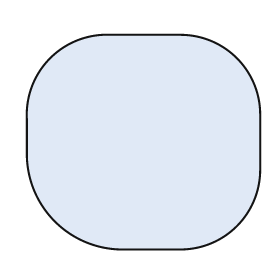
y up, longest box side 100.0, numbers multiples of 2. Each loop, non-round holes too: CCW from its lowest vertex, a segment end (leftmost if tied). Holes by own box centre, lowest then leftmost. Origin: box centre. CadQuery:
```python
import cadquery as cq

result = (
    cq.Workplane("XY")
    .moveTo(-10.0, -46.0)
    .lineTo(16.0, -46.0)
    .threePointArc((40.0, -36.0), (50.0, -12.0))
    .lineTo(50.0, 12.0)
    .threePointArc((40.0, 36.0), (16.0, 46.0))
    .lineTo(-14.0, 46.0)
    .threePointArc((-40.0, 36.0), (-50.0, 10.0))
    .lineTo(-50.0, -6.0)
    .threePointArc((-38.0, -34.0), (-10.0, -46.0))
    .close()
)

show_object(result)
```